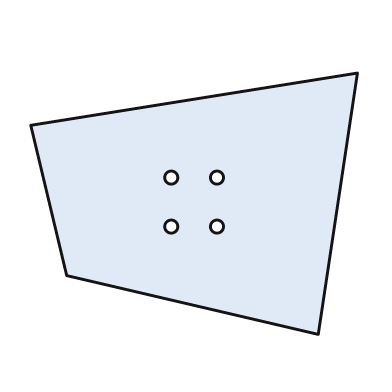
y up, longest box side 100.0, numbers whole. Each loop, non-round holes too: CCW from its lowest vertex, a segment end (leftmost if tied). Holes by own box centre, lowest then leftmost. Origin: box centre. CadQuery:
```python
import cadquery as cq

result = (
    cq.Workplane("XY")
    .moveTo(38.0, -40.0)
    .lineTo(50.0, 40.0)
    .lineTo(-50.0, 24.0)
    .lineTo(-39.0, -22.0)
    .close()
    .moveTo(-7.0, -7.0)
    .circle(2.0)
    .moveTo(7.0, -7.0)
    .circle(2.0)
    .moveTo(-7.0, 8.0)
    .circle(2.0)
    .moveTo(7.0, 8.0)
    .circle(2.0)
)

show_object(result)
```